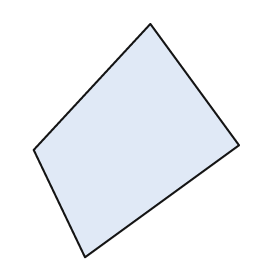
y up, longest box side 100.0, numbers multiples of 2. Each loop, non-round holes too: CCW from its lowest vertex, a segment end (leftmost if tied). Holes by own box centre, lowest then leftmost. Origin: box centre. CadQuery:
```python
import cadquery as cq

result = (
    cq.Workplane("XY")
    .moveTo(-22.0, -50.0)
    .lineTo(44.0, -2.0)
    .lineTo(6.0, 50.0)
    .lineTo(-44.0, -4.0)
    .close()
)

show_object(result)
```